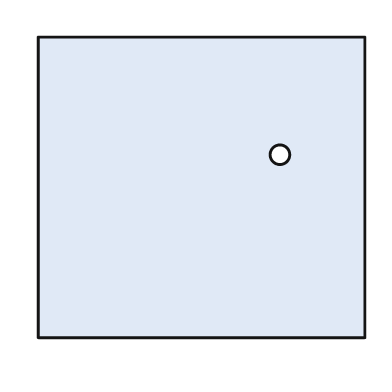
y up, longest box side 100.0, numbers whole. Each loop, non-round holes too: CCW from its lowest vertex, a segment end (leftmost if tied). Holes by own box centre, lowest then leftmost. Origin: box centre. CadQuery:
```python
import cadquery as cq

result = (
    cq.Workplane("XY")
    .moveTo(-50.0, -46.0)
    .lineTo(50.0, -46.0)
    .lineTo(50.0, 46.0)
    .lineTo(-50.0, 46.0)
    .close()
    .moveTo(24.0, 10.0)
    .circle(3.0)
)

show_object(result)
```